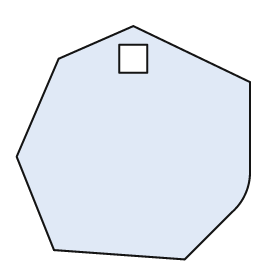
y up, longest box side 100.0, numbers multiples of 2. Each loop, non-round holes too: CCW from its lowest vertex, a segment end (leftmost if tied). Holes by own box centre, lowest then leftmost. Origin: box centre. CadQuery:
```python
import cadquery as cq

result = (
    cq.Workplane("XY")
    .moveTo(22.0, -50.0)
    .lineTo(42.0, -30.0)
    .threePointArc((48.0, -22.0), (50.0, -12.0))
    .lineTo(50.0, 26.0)
    .lineTo(0.0, 50.0)
    .lineTo(-32.0, 36.0)
    .lineTo(-50.0, -6.0)
    .lineTo(-34.0, -46.0)
    .close()
    .moveTo(-6.0, 30.0)
    .lineTo(6.0, 30.0)
    .lineTo(6.0, 42.0)
    .lineTo(-6.0, 42.0)
    .close()
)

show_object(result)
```